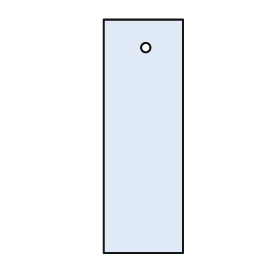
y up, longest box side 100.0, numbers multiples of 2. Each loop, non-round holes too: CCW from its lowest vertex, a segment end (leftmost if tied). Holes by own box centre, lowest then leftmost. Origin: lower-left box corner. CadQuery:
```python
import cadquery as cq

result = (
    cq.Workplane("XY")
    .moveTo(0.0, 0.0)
    .lineTo(34.0, 0.0)
    .lineTo(34.0, 100.0)
    .lineTo(0.0, 100.0)
    .close()
    .moveTo(18.0, 88.0)
    .circle(2.0)
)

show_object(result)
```